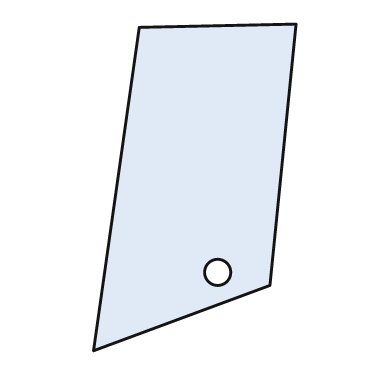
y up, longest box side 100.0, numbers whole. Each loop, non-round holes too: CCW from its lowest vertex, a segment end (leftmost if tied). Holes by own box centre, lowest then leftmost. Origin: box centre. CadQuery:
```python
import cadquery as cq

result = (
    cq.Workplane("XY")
    .moveTo(-31.0, -50.0)
    .lineTo(23.0, -30.0)
    .lineTo(31.0, 50.0)
    .lineTo(-17.0, 49.0)
    .close()
    .moveTo(7.0, -26.0)
    .circle(4.0)
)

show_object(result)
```